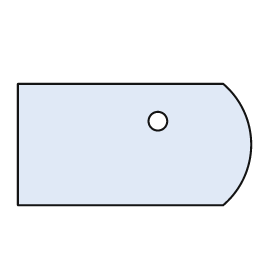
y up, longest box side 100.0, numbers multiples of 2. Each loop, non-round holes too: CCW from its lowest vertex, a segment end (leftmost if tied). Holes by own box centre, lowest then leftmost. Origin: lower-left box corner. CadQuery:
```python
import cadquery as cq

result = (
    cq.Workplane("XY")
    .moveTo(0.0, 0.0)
    .lineTo(88.0, 0.0)
    .threePointArc((100.0, 26.0), (88.0, 52.0))
    .lineTo(0.0, 52.0)
    .close()
    .moveTo(60.0, 36.0)
    .circle(4.0)
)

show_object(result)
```